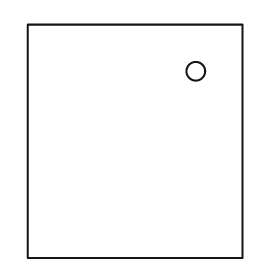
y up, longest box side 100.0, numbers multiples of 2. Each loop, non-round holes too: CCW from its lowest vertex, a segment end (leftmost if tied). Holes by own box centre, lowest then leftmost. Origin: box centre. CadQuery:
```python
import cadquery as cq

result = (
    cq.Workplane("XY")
    .moveTo(-46.0, -50.0)
    .lineTo(46.0, -50.0)
    .lineTo(46.0, 50.0)
    .lineTo(-46.0, 50.0)
    .close()
    .moveTo(26.0, 30.0)
    .circle(4.0)
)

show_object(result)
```